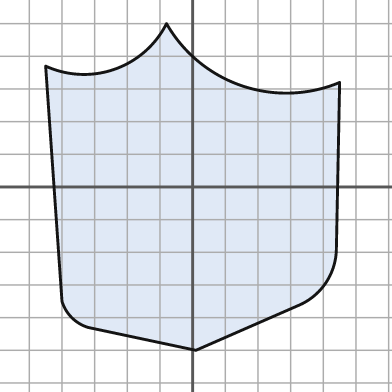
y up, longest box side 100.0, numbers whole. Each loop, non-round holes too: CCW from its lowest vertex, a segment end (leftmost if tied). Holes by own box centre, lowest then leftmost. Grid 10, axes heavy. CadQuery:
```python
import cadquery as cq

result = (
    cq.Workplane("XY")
    .moveTo(1.0, -50.0)
    .lineTo(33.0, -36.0)
    .threePointArc((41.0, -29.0), (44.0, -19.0))
    .lineTo(45.0, 32.0)
    .threePointArc((15.0, 31.0), (-8.0, 50.0))
    .threePointArc((-24.0, 36.0), (-45.0, 37.0))
    .lineTo(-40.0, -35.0)
    .threePointArc((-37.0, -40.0), (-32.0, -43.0))
    .close()
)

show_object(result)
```